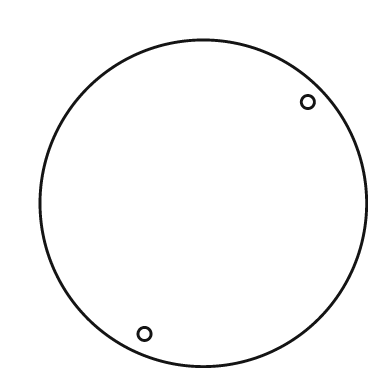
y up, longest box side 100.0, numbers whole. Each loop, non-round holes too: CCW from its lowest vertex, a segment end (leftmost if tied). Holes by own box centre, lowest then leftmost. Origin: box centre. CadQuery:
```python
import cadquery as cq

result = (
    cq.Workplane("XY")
    .moveTo(0.0, 0.0)
    .circle(50.0)
    .moveTo(-18.0, -40.0)
    .circle(2.0)
    .moveTo(32.0, 31.0)
    .circle(2.0)
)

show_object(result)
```